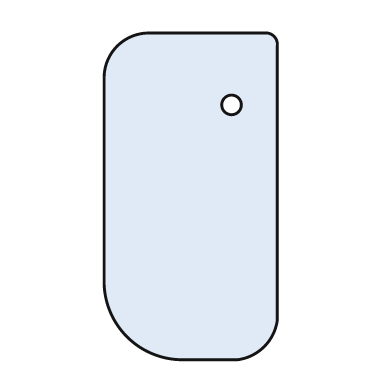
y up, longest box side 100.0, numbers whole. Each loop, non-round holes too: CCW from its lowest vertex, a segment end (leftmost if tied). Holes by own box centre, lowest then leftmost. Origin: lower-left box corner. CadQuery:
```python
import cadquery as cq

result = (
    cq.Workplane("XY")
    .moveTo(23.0, 0.0)
    .lineTo(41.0, 0.0)
    .threePointArc((49.0, 4.0), (53.0, 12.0))
    .lineTo(53.0, 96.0)
    .threePointArc((52.0, 99.0), (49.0, 100.0))
    .lineTo(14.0, 100.0)
    .threePointArc((4.0, 96.0), (0.0, 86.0))
    .lineTo(0.0, 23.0)
    .threePointArc((7.0, 7.0), (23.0, 0.0))
    .close()
    .moveTo(39.0, 78.0)
    .circle(3.0)
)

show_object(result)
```